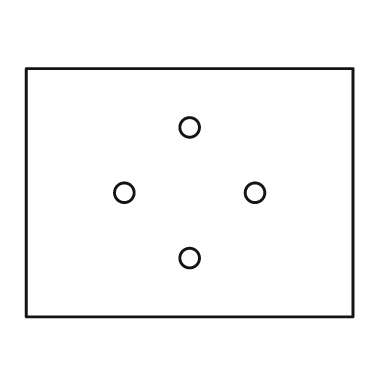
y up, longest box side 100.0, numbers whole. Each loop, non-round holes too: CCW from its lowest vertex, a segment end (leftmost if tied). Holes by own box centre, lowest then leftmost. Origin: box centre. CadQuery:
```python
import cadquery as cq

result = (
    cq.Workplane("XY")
    .moveTo(-50.0, -38.0)
    .lineTo(50.0, -38.0)
    .lineTo(50.0, 38.0)
    .lineTo(-50.0, 38.0)
    .close()
    .moveTo(0.0, -20.0)
    .circle(3.0)
    .moveTo(-20.0, 0.0)
    .circle(3.0)
    .moveTo(20.0, 0.0)
    .circle(3.0)
    .moveTo(0.0, 20.0)
    .circle(3.0)
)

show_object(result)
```